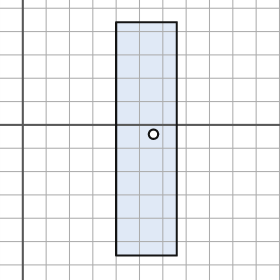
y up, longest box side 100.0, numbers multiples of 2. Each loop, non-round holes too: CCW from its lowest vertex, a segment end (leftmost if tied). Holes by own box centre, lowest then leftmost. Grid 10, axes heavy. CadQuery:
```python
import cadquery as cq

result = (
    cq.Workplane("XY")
    .moveTo(40.0, -56.0)
    .lineTo(66.0, -56.0)
    .lineTo(66.0, 44.0)
    .lineTo(40.0, 44.0)
    .close()
    .moveTo(56.0, -4.0)
    .circle(2.0)
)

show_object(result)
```